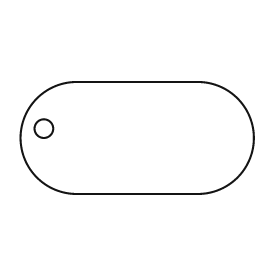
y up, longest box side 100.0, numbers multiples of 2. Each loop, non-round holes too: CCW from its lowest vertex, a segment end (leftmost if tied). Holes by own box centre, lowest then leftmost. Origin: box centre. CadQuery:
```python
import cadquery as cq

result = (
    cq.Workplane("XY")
    .moveTo(-26.0, -24.0)
    .lineTo(26.0, -24.0)
    .threePointArc((50.0, 0.0), (26.0, 24.0))
    .lineTo(-26.0, 24.0)
    .threePointArc((-50.0, 0.0), (-26.0, -24.0))
    .close()
    .moveTo(-40.0, 4.0)
    .circle(4.0)
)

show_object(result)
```